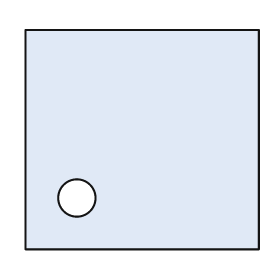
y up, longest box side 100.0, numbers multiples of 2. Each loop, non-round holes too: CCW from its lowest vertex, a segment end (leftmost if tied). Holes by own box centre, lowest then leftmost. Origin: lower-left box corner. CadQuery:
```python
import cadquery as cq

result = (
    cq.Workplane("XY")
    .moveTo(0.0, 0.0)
    .lineTo(100.0, 0.0)
    .lineTo(100.0, 94.0)
    .lineTo(0.0, 94.0)
    .close()
    .moveTo(22.0, 22.0)
    .circle(8.0)
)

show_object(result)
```